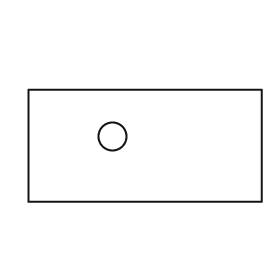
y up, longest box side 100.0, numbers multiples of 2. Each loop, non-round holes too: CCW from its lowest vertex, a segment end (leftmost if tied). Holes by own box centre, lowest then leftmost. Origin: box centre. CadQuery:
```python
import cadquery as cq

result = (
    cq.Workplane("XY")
    .moveTo(-50.0, -24.0)
    .lineTo(50.0, -24.0)
    .lineTo(50.0, 24.0)
    .lineTo(-50.0, 24.0)
    .close()
    .moveTo(-14.0, 4.0)
    .circle(6.0)
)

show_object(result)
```